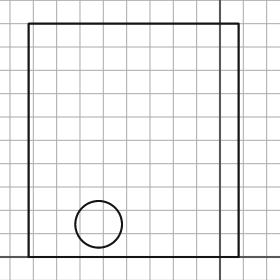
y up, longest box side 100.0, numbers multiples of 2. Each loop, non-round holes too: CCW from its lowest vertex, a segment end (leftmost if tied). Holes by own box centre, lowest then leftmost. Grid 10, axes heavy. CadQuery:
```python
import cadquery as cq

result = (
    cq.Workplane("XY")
    .moveTo(-82.0, 0.0)
    .lineTo(8.0, 0.0)
    .lineTo(8.0, 100.0)
    .lineTo(-82.0, 100.0)
    .close()
    .moveTo(-52.0, 14.0)
    .circle(10.0)
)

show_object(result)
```